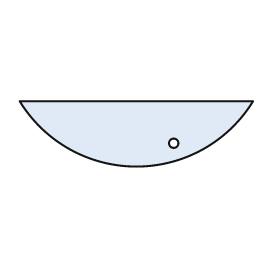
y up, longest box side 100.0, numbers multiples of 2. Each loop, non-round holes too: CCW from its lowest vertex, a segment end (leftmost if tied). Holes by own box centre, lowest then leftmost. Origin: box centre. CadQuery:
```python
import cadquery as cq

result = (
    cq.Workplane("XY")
    .moveTo(-50.0, 14.0)
    .threePointArc((0.0, -14.0), (50.0, 14.0))
    .close()
    .moveTo(16.0, -4.0)
    .circle(2.0)
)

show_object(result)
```